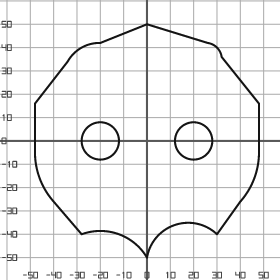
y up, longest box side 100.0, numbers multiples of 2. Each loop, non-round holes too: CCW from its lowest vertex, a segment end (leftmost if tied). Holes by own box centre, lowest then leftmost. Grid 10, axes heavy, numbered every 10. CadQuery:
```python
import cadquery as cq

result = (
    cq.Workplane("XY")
    .moveTo(0.0, -50.0)
    .threePointArc((12.0, -36.0), (30.0, -40.0))
    .lineTo(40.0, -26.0)
    .threePointArc((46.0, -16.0), (48.0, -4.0))
    .lineTo(48.0, 16.0)
    .lineTo(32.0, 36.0)
    .threePointArc((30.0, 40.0), (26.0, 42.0))
    .lineTo(0.0, 50.0)
    .lineTo(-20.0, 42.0)
    .threePointArc((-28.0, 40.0), (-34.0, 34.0))
    .lineTo(-48.0, 16.0)
    .lineTo(-48.0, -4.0)
    .threePointArc((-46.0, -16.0), (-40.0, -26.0))
    .lineTo(-28.0, -40.0)
    .threePointArc((-12.0, -40.0), (0.0, -50.0))
    .close()
    .moveTo(-20.0, 0.0)
    .circle(8.0)
    .moveTo(20.0, 0.0)
    .circle(8.0)
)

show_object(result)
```